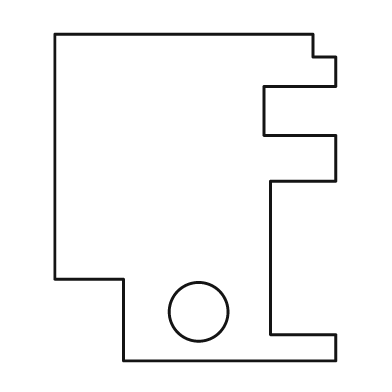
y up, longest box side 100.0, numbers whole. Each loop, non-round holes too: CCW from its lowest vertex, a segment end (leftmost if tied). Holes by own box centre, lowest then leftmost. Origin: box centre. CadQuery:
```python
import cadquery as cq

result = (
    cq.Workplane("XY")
    .moveTo(-22.0, -50.0)
    .lineTo(43.0, -50.0)
    .lineTo(43.0, -42.0)
    .lineTo(23.0, -42.0)
    .lineTo(23.0, 5.0)
    .lineTo(43.0, 5.0)
    .lineTo(43.0, 19.0)
    .lineTo(21.0, 19.0)
    .lineTo(21.0, 34.0)
    .lineTo(43.0, 34.0)
    .lineTo(43.0, 43.0)
    .lineTo(36.0, 43.0)
    .lineTo(36.0, 50.0)
    .lineTo(-43.0, 50.0)
    .lineTo(-43.0, -25.0)
    .lineTo(-22.0, -25.0)
    .close()
    .moveTo(1.0, -35.0)
    .circle(9.0)
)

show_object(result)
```